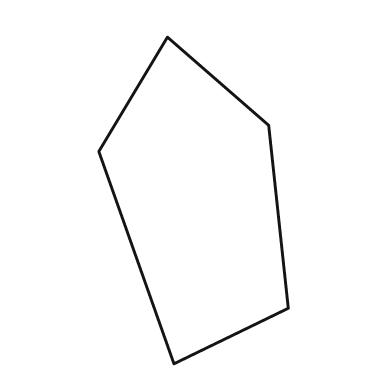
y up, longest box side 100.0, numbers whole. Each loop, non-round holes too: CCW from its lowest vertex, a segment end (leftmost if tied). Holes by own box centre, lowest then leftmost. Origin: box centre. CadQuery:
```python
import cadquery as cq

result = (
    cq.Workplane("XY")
    .moveTo(-6.0, -50.0)
    .lineTo(29.0, -33.0)
    .lineTo(23.0, 23.0)
    .lineTo(-8.0, 50.0)
    .lineTo(-29.0, 15.0)
    .close()
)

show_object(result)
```